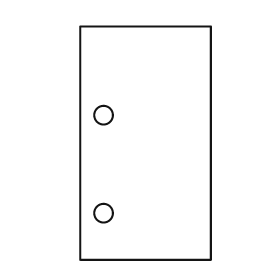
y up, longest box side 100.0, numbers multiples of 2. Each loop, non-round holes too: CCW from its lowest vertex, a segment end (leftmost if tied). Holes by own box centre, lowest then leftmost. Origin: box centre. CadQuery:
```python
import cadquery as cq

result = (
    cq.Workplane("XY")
    .moveTo(-28.0, -50.0)
    .lineTo(28.0, -50.0)
    .lineTo(28.0, 50.0)
    .lineTo(-28.0, 50.0)
    .close()
    .moveTo(-18.0, -30.0)
    .circle(4.0)
    .moveTo(-18.0, 12.0)
    .circle(4.0)
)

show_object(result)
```